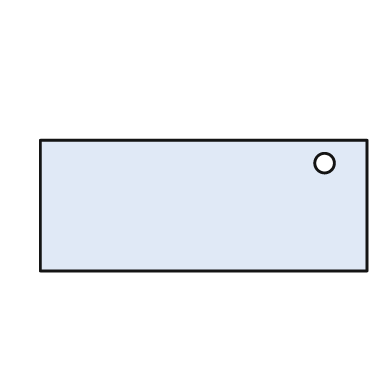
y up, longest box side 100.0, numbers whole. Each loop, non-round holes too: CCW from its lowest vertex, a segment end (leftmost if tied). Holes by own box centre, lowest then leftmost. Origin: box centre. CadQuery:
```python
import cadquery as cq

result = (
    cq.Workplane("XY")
    .moveTo(-50.0, -20.0)
    .lineTo(50.0, -20.0)
    .lineTo(50.0, 20.0)
    .lineTo(-50.0, 20.0)
    .close()
    .moveTo(37.0, 13.0)
    .circle(3.0)
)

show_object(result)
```